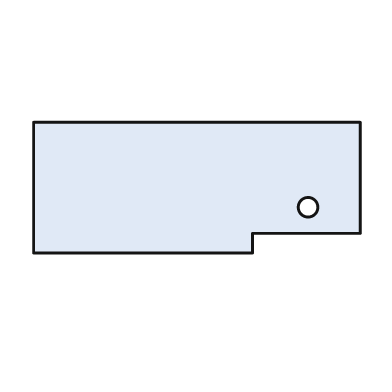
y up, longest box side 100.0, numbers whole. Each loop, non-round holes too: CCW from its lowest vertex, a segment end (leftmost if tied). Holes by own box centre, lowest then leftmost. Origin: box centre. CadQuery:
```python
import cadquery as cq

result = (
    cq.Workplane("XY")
    .moveTo(-50.0, -20.0)
    .lineTo(17.0, -20.0)
    .lineTo(17.0, -14.0)
    .lineTo(50.0, -14.0)
    .lineTo(50.0, 20.0)
    .lineTo(-50.0, 20.0)
    .close()
    .moveTo(34.0, -6.0)
    .circle(3.0)
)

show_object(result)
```